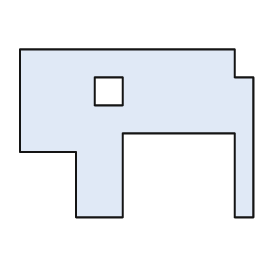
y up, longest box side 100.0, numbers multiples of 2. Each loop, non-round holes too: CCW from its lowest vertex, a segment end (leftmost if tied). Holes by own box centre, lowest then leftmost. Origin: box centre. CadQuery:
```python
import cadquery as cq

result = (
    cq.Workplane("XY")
    .moveTo(-26.0, -36.0)
    .lineTo(-6.0, -36.0)
    .lineTo(-6.0, 0.0)
    .lineTo(42.0, 0.0)
    .lineTo(42.0, -36.0)
    .lineTo(50.0, -36.0)
    .lineTo(50.0, 24.0)
    .lineTo(42.0, 24.0)
    .lineTo(42.0, 36.0)
    .lineTo(-50.0, 36.0)
    .lineTo(-50.0, -8.0)
    .lineTo(-26.0, -8.0)
    .close()
    .moveTo(-18.0, 12.0)
    .lineTo(-6.0, 12.0)
    .lineTo(-6.0, 24.0)
    .lineTo(-18.0, 24.0)
    .close()
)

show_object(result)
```